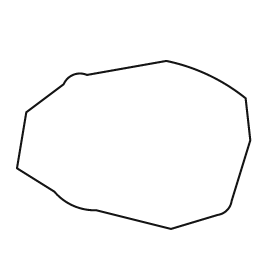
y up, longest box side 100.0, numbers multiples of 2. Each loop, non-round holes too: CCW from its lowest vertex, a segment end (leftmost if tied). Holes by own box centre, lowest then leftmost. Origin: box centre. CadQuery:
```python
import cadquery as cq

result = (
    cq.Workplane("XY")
    .moveTo(16.0, -36.0)
    .lineTo(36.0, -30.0)
    .threePointArc((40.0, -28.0), (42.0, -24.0))
    .lineTo(50.0, 2.0)
    .lineTo(48.0, 20.0)
    .threePointArc((32.0, 30.0), (14.0, 36.0))
    .lineTo(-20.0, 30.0)
    .threePointArc((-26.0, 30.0), (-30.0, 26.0))
    .lineTo(-46.0, 14.0)
    .lineTo(-50.0, -10.0)
    .lineTo(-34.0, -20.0)
    .threePointArc((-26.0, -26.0), (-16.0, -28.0))
    .close()
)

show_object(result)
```